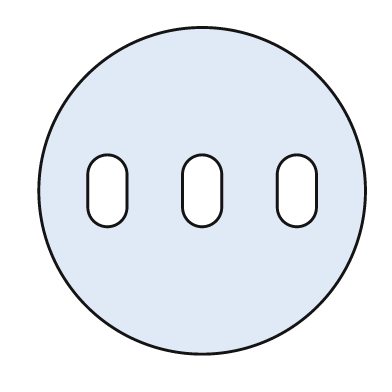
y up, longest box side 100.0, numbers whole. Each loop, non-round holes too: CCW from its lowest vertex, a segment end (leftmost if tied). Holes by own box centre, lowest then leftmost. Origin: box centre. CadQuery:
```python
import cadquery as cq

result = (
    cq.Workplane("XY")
    .moveTo(0.0, 0.0)
    .circle(50.0)
    .moveTo(-35.0, -5.0)
    .threePointArc((-29.0, -11.0), (-23.0, -5.0))
    .lineTo(-23.0, 5.0)
    .threePointArc((-29.0, 11.0), (-35.0, 5.0))
    .close()
    .moveTo(-6.0, -5.0)
    .threePointArc((0.0, -11.0), (6.0, -5.0))
    .lineTo(6.0, 5.0)
    .threePointArc((0.0, 11.0), (-6.0, 5.0))
    .close()
    .moveTo(23.0, -5.0)
    .threePointArc((29.0, -11.0), (35.0, -5.0))
    .lineTo(35.0, 5.0)
    .threePointArc((29.0, 11.0), (23.0, 5.0))
    .close()
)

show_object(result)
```